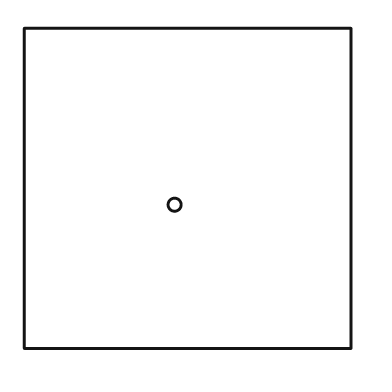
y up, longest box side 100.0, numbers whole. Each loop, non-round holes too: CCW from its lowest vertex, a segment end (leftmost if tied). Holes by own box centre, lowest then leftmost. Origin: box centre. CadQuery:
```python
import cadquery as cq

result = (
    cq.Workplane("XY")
    .moveTo(-50.0, -49.0)
    .lineTo(50.0, -49.0)
    .lineTo(50.0, 49.0)
    .lineTo(-50.0, 49.0)
    .close()
    .moveTo(-4.0, -5.0)
    .circle(2.0)
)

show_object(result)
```